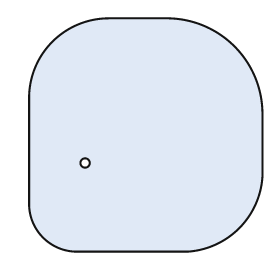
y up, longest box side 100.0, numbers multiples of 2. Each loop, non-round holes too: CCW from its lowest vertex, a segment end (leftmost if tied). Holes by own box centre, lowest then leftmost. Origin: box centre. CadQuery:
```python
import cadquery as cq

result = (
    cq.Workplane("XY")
    .moveTo(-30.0, -50.0)
    .lineTo(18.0, -50.0)
    .threePointArc((40.0, -40.0), (50.0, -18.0))
    .lineTo(50.0, 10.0)
    .threePointArc((38.0, 38.0), (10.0, 50.0))
    .lineTo(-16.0, 50.0)
    .threePointArc((-40.0, 40.0), (-50.0, 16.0))
    .lineTo(-50.0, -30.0)
    .threePointArc((-44.0, -44.0), (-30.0, -50.0))
    .close()
    .moveTo(-26.0, -12.0)
    .circle(2.0)
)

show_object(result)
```